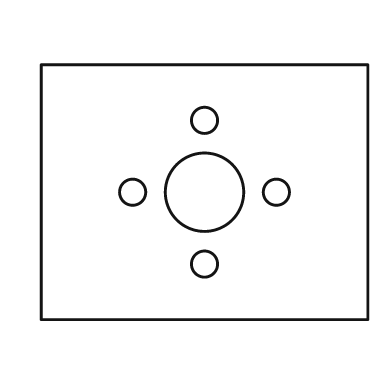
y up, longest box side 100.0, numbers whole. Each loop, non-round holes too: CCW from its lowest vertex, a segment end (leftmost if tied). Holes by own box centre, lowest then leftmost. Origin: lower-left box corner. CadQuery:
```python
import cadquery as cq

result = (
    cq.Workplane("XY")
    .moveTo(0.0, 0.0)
    .lineTo(100.0, 0.0)
    .lineTo(100.0, 78.0)
    .lineTo(0.0, 78.0)
    .close()
    .moveTo(50.0, 17.0)
    .circle(4.0)
    .moveTo(28.0, 39.0)
    .circle(4.0)
    .moveTo(50.0, 39.0)
    .circle(12.0)
    .moveTo(72.0, 39.0)
    .circle(4.0)
    .moveTo(50.0, 61.0)
    .circle(4.0)
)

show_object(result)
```